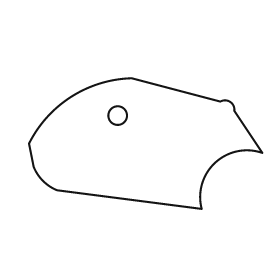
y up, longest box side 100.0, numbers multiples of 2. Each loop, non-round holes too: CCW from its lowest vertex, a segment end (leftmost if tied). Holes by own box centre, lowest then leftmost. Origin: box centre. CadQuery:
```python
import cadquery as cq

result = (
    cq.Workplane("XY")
    .moveTo(24.0, -28.0)
    .threePointArc((30.0, -8.0), (50.0, -4.0))
    .lineTo(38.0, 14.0)
    .threePointArc((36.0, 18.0), (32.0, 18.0))
    .lineTo(-6.0, 28.0)
    .threePointArc((-32.0, 20.0), (-50.0, 0.0))
    .lineTo(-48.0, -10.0)
    .threePointArc((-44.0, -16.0), (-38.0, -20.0))
    .close()
    .moveTo(-12.0, 12.0)
    .circle(4.0)
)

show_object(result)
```